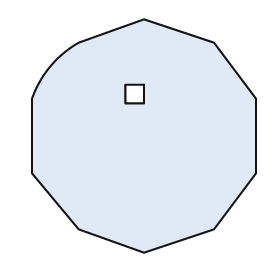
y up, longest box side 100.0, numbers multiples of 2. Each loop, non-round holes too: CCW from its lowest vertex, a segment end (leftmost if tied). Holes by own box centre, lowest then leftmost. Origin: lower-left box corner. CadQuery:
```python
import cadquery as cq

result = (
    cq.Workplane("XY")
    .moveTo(48.0, 0.0)
    .lineTo(78.0, 10.0)
    .lineTo(96.0, 34.0)
    .lineTo(96.0, 66.0)
    .lineTo(78.0, 90.0)
    .lineTo(48.0, 100.0)
    .lineTo(20.0, 90.0)
    .threePointArc((8.0, 80.0), (0.0, 66.0))
    .lineTo(0.0, 34.0)
    .lineTo(20.0, 10.0)
    .close()
    .moveTo(40.0, 64.0)
    .lineTo(48.0, 64.0)
    .lineTo(48.0, 72.0)
    .lineTo(40.0, 72.0)
    .close()
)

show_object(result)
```